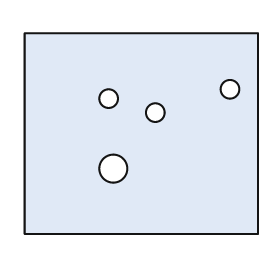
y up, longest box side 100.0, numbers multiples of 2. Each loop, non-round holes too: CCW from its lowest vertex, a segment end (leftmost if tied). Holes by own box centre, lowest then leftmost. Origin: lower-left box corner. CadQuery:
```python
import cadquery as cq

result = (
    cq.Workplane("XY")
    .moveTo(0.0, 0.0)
    .lineTo(100.0, 0.0)
    .lineTo(100.0, 86.0)
    .lineTo(0.0, 86.0)
    .close()
    .moveTo(38.0, 28.0)
    .circle(6.0)
    .moveTo(56.0, 52.0)
    .circle(4.0)
    .moveTo(36.0, 58.0)
    .circle(4.0)
    .moveTo(88.0, 62.0)
    .circle(4.0)
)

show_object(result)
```